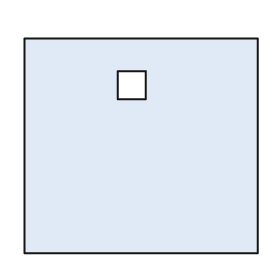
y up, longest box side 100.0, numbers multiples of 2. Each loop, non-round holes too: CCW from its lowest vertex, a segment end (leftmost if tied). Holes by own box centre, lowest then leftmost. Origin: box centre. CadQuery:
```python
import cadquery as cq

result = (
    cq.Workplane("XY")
    .moveTo(-50.0, -46.0)
    .lineTo(50.0, -46.0)
    .lineTo(50.0, 46.0)
    .lineTo(-50.0, 46.0)
    .close()
    .moveTo(-10.0, 20.0)
    .lineTo(2.0, 20.0)
    .lineTo(2.0, 32.0)
    .lineTo(-10.0, 32.0)
    .close()
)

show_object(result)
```